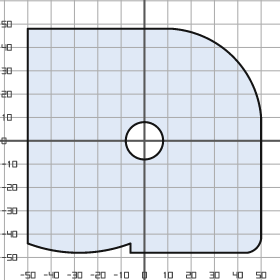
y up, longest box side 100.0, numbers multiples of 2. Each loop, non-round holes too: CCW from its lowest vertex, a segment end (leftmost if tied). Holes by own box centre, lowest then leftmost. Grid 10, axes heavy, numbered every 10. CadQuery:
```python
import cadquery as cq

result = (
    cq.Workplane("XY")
    .moveTo(-6.0, -48.0)
    .lineTo(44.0, -48.0)
    .threePointArc((48.0, -46.0), (50.0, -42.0))
    .lineTo(50.0, 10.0)
    .threePointArc((38.0, 36.0), (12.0, 48.0))
    .lineTo(-50.0, 48.0)
    .lineTo(-50.0, -44.0)
    .threePointArc((-28.0, -48.0), (-6.0, -44.0))
    .close()
    .moveTo(0.0, 0.0)
    .circle(8.0)
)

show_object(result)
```